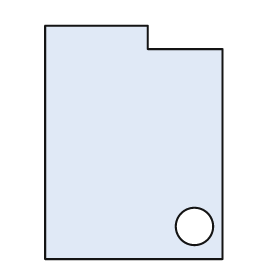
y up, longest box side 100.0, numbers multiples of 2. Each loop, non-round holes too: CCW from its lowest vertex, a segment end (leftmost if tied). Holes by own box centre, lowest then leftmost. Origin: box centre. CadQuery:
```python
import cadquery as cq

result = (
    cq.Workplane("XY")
    .moveTo(-38.0, -50.0)
    .lineTo(38.0, -50.0)
    .lineTo(38.0, 40.0)
    .lineTo(6.0, 40.0)
    .lineTo(6.0, 50.0)
    .lineTo(-38.0, 50.0)
    .close()
    .moveTo(26.0, -36.0)
    .circle(8.0)
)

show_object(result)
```